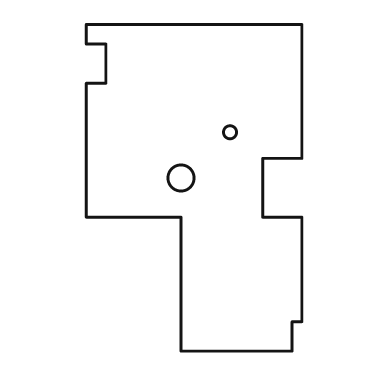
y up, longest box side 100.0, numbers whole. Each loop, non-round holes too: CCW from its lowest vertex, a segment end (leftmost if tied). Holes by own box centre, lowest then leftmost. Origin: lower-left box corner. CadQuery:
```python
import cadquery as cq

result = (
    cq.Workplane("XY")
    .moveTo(29.0, 0.0)
    .lineTo(63.0, 0.0)
    .lineTo(63.0, 9.0)
    .lineTo(66.0, 9.0)
    .lineTo(66.0, 41.0)
    .lineTo(54.0, 41.0)
    .lineTo(54.0, 59.0)
    .lineTo(66.0, 59.0)
    .lineTo(66.0, 100.0)
    .lineTo(0.0, 100.0)
    .lineTo(0.0, 94.0)
    .lineTo(6.0, 94.0)
    .lineTo(6.0, 82.0)
    .lineTo(0.0, 82.0)
    .lineTo(0.0, 41.0)
    .lineTo(29.0, 41.0)
    .close()
    .moveTo(29.0, 53.0)
    .circle(4.0)
    .moveTo(44.0, 67.0)
    .circle(2.0)
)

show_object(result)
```